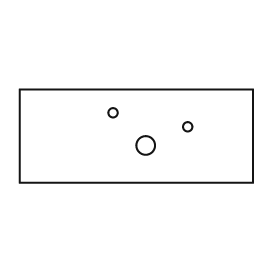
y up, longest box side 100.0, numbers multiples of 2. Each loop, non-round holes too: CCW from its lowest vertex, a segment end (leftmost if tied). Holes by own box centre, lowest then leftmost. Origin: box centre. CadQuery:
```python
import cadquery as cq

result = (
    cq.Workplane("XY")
    .moveTo(-50.0, -20.0)
    .lineTo(50.0, -20.0)
    .lineTo(50.0, 20.0)
    .lineTo(-50.0, 20.0)
    .close()
    .moveTo(4.0, -4.0)
    .circle(4.0)
    .moveTo(22.0, 4.0)
    .circle(2.0)
    .moveTo(-10.0, 10.0)
    .circle(2.0)
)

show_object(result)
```